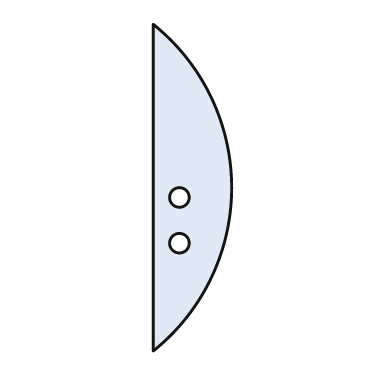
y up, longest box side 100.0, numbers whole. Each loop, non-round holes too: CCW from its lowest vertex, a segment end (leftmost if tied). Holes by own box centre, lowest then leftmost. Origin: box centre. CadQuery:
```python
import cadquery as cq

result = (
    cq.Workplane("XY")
    .moveTo(-12.0, -50.0)
    .threePointArc((12.0, 0.0), (-12.0, 50.0))
    .close()
    .moveTo(-4.0, -17.0)
    .circle(3.0)
    .moveTo(-4.0, -3.0)
    .circle(3.0)
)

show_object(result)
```